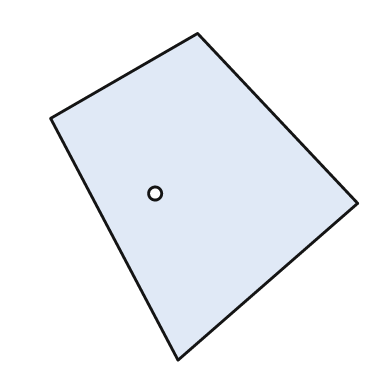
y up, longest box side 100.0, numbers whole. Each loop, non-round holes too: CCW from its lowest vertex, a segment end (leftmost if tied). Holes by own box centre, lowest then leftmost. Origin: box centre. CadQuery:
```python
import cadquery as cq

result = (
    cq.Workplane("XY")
    .moveTo(-8.0, -50.0)
    .lineTo(47.0, -2.0)
    .lineTo(-2.0, 50.0)
    .lineTo(-47.0, 24.0)
    .close()
    .moveTo(-15.0, 1.0)
    .circle(2.0)
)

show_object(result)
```